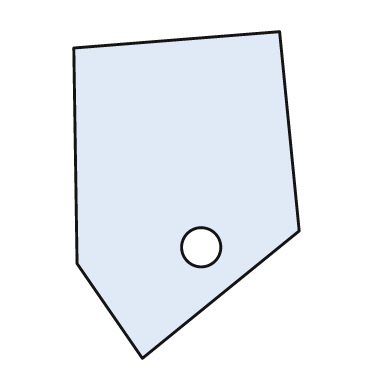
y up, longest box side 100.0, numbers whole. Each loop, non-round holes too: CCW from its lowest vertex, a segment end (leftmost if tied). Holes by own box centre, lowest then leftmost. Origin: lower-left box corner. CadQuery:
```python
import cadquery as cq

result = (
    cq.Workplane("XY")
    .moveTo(21.0, 0.0)
    .lineTo(69.0, 39.0)
    .lineTo(63.0, 100.0)
    .lineTo(0.0, 95.0)
    .lineTo(1.0, 29.0)
    .close()
    .moveTo(39.0, 34.0)
    .circle(6.0)
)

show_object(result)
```